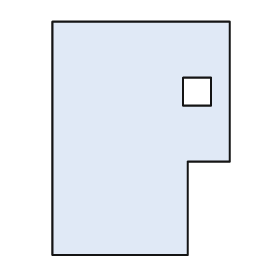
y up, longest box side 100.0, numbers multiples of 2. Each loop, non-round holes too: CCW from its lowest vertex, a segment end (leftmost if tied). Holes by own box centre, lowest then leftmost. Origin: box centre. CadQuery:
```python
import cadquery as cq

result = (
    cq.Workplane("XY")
    .moveTo(-38.0, -50.0)
    .lineTo(20.0, -50.0)
    .lineTo(20.0, -10.0)
    .lineTo(38.0, -10.0)
    .lineTo(38.0, 50.0)
    .lineTo(-38.0, 50.0)
    .close()
    .moveTo(18.0, 14.0)
    .lineTo(30.0, 14.0)
    .lineTo(30.0, 26.0)
    .lineTo(18.0, 26.0)
    .close()
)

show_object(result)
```